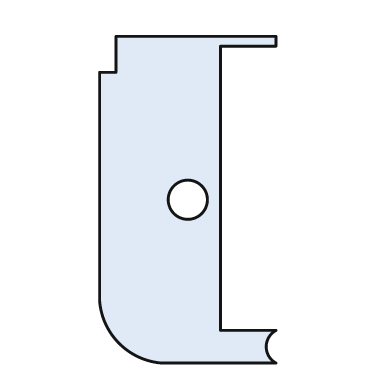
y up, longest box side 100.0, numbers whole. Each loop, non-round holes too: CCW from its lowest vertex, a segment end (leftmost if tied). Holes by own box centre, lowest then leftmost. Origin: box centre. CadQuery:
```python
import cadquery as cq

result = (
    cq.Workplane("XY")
    .moveTo(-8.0, -50.0)
    .lineTo(27.0, -50.0)
    .threePointArc((24.0, -45.0), (27.0, -40.0))
    .lineTo(10.0, -40.0)
    .lineTo(10.0, 47.0)
    .lineTo(27.0, 47.0)
    .lineTo(27.0, 50.0)
    .lineTo(-22.0, 50.0)
    .lineTo(-22.0, 39.0)
    .lineTo(-27.0, 39.0)
    .lineTo(-27.0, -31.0)
    .threePointArc((-21.0, -44.0), (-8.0, -50.0))
    .close()
    .moveTo(0.0, 0.0)
    .circle(6.0)
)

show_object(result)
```